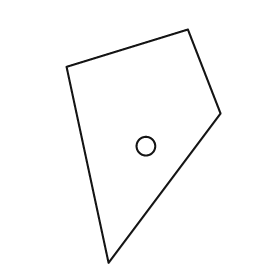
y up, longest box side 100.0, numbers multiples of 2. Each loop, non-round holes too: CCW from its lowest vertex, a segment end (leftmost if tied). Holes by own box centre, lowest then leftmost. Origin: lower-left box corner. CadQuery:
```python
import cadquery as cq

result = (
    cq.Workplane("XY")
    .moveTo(18.0, 0.0)
    .lineTo(66.0, 64.0)
    .lineTo(52.0, 100.0)
    .lineTo(0.0, 84.0)
    .close()
    .moveTo(34.0, 50.0)
    .circle(4.0)
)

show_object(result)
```